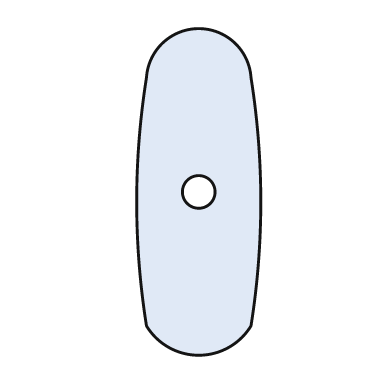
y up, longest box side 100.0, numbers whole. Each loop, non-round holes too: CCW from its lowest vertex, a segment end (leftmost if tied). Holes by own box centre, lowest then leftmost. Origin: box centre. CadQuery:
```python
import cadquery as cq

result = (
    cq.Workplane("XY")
    .moveTo(-16.0, -41.0)
    .threePointArc((0.0, -50.0), (16.0, -41.0))
    .threePointArc((19.0, -3.0), (16.0, 35.0))
    .threePointArc((0.0, 50.0), (-16.0, 35.0))
    .threePointArc((-19.0, -3.0), (-16.0, -41.0))
    .close()
    .moveTo(0.0, 0.0)
    .circle(5.0)
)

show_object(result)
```